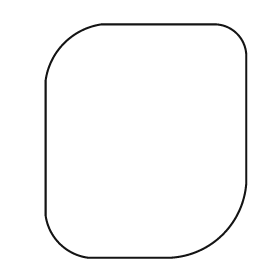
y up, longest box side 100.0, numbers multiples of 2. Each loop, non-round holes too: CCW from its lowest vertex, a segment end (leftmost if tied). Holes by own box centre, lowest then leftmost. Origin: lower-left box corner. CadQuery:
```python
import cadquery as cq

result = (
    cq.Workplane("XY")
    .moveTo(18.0, 0.0)
    .lineTo(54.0, 0.0)
    .threePointArc((76.0, 10.0), (86.0, 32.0))
    .lineTo(86.0, 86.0)
    .threePointArc((82.0, 96.0), (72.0, 100.0))
    .lineTo(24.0, 100.0)
    .threePointArc((8.0, 92.0), (0.0, 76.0))
    .lineTo(0.0, 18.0)
    .threePointArc((6.0, 6.0), (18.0, 0.0))
    .close()
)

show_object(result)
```